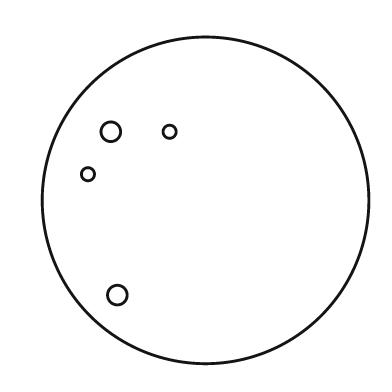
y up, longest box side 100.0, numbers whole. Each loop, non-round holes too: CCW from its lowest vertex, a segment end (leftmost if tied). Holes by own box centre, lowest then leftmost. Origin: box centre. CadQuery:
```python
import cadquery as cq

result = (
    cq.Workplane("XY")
    .moveTo(0.0, 0.0)
    .circle(50.0)
    .moveTo(-27.0, -29.0)
    .circle(3.0)
    .moveTo(-36.0, 8.0)
    .circle(2.0)
    .moveTo(-29.0, 21.0)
    .circle(3.0)
    .moveTo(-11.0, 21.0)
    .circle(2.0)
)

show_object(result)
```